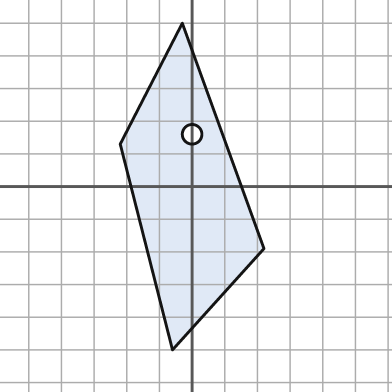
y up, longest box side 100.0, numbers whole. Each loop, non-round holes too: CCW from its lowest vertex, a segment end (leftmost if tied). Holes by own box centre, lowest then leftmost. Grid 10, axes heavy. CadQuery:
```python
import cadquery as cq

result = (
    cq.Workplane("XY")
    .moveTo(-6.0, -50.0)
    .lineTo(22.0, -19.0)
    .lineTo(-3.0, 50.0)
    .lineTo(-22.0, 13.0)
    .close()
    .moveTo(0.0, 16.0)
    .circle(3.0)
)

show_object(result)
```